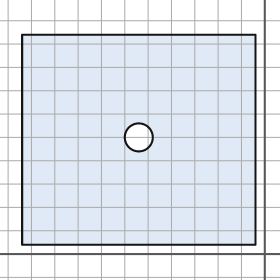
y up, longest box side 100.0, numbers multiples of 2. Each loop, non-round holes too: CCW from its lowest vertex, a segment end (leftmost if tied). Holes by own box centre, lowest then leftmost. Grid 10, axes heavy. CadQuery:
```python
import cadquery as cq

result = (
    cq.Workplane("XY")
    .moveTo(-104.0, 4.0)
    .lineTo(-4.0, 4.0)
    .lineTo(-4.0, 94.0)
    .lineTo(-104.0, 94.0)
    .close()
    .moveTo(-54.0, 50.0)
    .circle(6.0)
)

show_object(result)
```